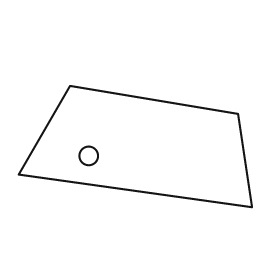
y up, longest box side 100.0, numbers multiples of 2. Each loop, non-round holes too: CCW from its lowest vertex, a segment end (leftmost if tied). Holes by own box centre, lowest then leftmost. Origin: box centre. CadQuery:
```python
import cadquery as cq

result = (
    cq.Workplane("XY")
    .moveTo(50.0, -26.0)
    .lineTo(44.0, 14.0)
    .lineTo(-28.0, 26.0)
    .lineTo(-50.0, -12.0)
    .close()
    .moveTo(-20.0, -4.0)
    .circle(4.0)
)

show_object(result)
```